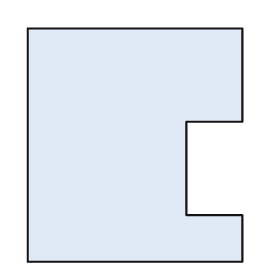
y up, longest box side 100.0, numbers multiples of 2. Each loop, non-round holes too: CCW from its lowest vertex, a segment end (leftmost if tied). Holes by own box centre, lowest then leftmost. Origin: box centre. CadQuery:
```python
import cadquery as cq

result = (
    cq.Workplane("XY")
    .moveTo(-46.0, -50.0)
    .lineTo(46.0, -50.0)
    .lineTo(46.0, -30.0)
    .lineTo(22.0, -30.0)
    .lineTo(22.0, 10.0)
    .lineTo(46.0, 10.0)
    .lineTo(46.0, 50.0)
    .lineTo(-46.0, 50.0)
    .close()
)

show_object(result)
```